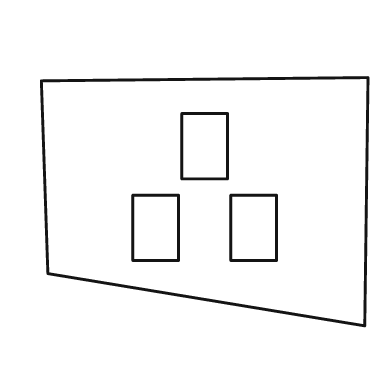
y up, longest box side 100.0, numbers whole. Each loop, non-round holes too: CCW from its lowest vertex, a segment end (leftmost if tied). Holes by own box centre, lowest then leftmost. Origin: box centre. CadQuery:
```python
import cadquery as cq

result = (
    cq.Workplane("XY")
    .moveTo(49.0, -38.0)
    .lineTo(50.0, 38.0)
    .lineTo(-50.0, 37.0)
    .lineTo(-48.0, -22.0)
    .close()
    .moveTo(-22.0, -18.0)
    .lineTo(-8.0, -18.0)
    .lineTo(-8.0, 2.0)
    .lineTo(-22.0, 2.0)
    .close()
    .moveTo(8.0, -18.0)
    .lineTo(22.0, -18.0)
    .lineTo(22.0, 2.0)
    .lineTo(8.0, 2.0)
    .close()
    .moveTo(-7.0, 7.0)
    .lineTo(7.0, 7.0)
    .lineTo(7.0, 27.0)
    .lineTo(-7.0, 27.0)
    .close()
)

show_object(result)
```